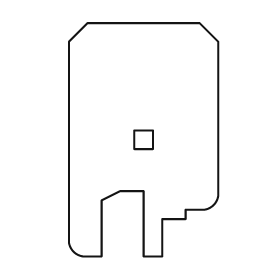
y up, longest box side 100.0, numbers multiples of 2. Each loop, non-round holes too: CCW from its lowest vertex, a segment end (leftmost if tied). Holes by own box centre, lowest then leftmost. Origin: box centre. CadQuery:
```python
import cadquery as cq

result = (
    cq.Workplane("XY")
    .moveTo(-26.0, -50.0)
    .lineTo(-18.0, -50.0)
    .lineTo(-18.0, -26.0)
    .lineTo(-10.0, -22.0)
    .lineTo(0.0, -22.0)
    .lineTo(0.0, -50.0)
    .lineTo(8.0, -50.0)
    .lineTo(8.0, -34.0)
    .lineTo(18.0, -34.0)
    .lineTo(18.0, -30.0)
    .lineTo(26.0, -30.0)
    .threePointArc((30.0, -28.0), (32.0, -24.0))
    .lineTo(32.0, 42.0)
    .lineTo(24.0, 50.0)
    .lineTo(-24.0, 50.0)
    .lineTo(-32.0, 42.0)
    .lineTo(-32.0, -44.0)
    .threePointArc((-30.0, -48.0), (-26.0, -50.0))
    .close()
    .moveTo(-4.0, -4.0)
    .lineTo(4.0, -4.0)
    .lineTo(4.0, 4.0)
    .lineTo(-4.0, 4.0)
    .close()
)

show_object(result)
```